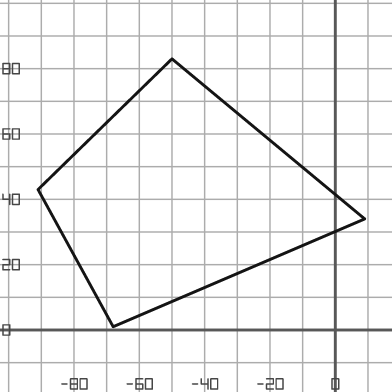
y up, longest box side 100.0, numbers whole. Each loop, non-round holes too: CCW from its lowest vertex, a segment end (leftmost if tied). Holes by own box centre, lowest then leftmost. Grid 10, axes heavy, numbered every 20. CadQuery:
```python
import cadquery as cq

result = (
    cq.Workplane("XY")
    .moveTo(-68.0, 1.0)
    .lineTo(9.0, 34.0)
    .lineTo(-50.0, 83.0)
    .lineTo(-91.0, 43.0)
    .close()
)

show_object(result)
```